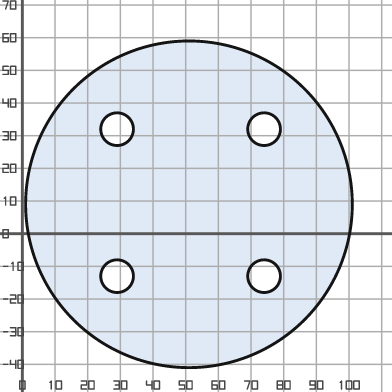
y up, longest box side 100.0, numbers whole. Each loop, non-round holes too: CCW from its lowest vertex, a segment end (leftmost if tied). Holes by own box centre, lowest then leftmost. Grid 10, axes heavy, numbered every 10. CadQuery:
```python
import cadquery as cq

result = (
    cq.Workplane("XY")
    .moveTo(51.0, 9.0)
    .circle(50.0)
    .moveTo(29.0, -13.0)
    .circle(5.0)
    .moveTo(74.0, -13.0)
    .circle(5.0)
    .moveTo(29.0, 32.0)
    .circle(5.0)
    .moveTo(74.0, 32.0)
    .circle(5.0)
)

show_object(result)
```